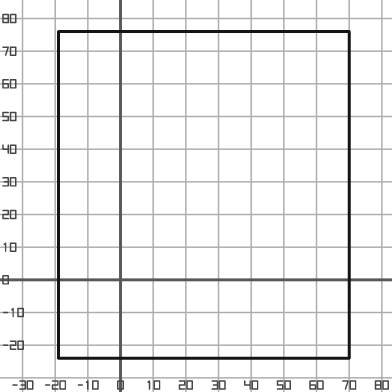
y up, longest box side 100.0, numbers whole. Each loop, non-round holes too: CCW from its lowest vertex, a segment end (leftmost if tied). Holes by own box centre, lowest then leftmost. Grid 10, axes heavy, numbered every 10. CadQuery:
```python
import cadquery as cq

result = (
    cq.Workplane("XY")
    .moveTo(-19.0, -24.0)
    .lineTo(70.0, -24.0)
    .lineTo(70.0, 76.0)
    .lineTo(-19.0, 76.0)
    .close()
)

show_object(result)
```